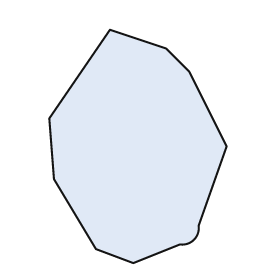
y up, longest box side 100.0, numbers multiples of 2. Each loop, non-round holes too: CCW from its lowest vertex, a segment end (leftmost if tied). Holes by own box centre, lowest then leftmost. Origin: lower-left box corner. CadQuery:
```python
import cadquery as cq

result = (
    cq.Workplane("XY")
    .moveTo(36.0, 0.0)
    .lineTo(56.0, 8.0)
    .threePointArc((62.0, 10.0), (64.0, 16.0))
    .lineTo(76.0, 50.0)
    .lineTo(60.0, 82.0)
    .lineTo(50.0, 92.0)
    .lineTo(26.0, 100.0)
    .lineTo(0.0, 62.0)
    .lineTo(2.0, 36.0)
    .lineTo(20.0, 6.0)
    .close()
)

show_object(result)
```